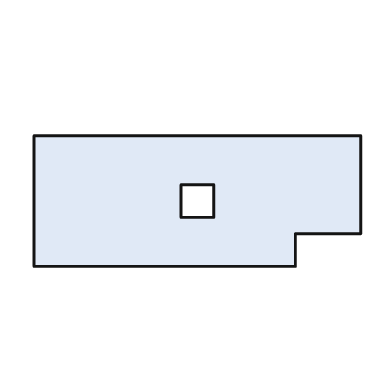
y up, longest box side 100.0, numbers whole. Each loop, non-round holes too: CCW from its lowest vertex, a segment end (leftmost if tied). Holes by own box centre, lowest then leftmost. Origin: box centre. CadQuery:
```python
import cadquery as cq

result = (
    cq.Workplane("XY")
    .moveTo(-50.0, -20.0)
    .lineTo(30.0, -20.0)
    .lineTo(30.0, -10.0)
    .lineTo(50.0, -10.0)
    .lineTo(50.0, 20.0)
    .lineTo(-50.0, 20.0)
    .close()
    .moveTo(-5.0, -5.0)
    .lineTo(5.0, -5.0)
    .lineTo(5.0, 5.0)
    .lineTo(-5.0, 5.0)
    .close()
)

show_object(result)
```